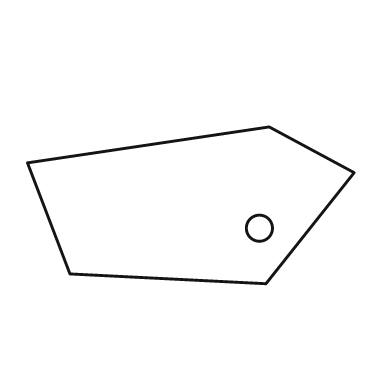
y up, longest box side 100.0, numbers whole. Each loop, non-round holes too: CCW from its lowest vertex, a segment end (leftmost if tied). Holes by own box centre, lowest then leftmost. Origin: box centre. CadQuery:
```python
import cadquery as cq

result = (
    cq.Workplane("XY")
    .moveTo(23.0, -24.0)
    .lineTo(50.0, 10.0)
    .lineTo(24.0, 24.0)
    .lineTo(-50.0, 13.0)
    .lineTo(-37.0, -21.0)
    .close()
    .moveTo(21.0, -7.0)
    .circle(4.0)
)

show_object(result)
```